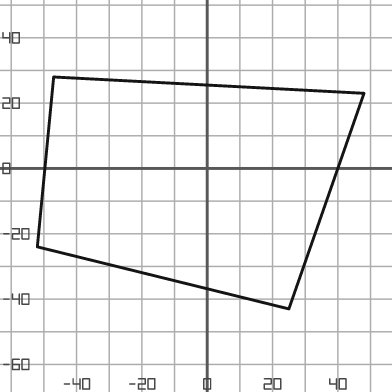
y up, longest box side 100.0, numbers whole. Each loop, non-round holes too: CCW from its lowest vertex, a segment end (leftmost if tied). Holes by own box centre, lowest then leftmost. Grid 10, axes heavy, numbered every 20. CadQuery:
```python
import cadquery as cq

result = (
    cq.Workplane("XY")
    .moveTo(25.0, -43.0)
    .lineTo(48.0, 23.0)
    .lineTo(-47.0, 28.0)
    .lineTo(-52.0, -24.0)
    .close()
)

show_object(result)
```